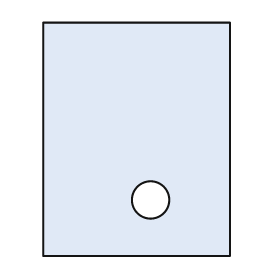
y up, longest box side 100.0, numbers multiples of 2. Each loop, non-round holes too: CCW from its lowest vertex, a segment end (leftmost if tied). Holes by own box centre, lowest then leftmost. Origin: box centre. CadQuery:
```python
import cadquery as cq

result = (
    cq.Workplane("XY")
    .moveTo(-40.0, -50.0)
    .lineTo(40.0, -50.0)
    .lineTo(40.0, 50.0)
    .lineTo(-40.0, 50.0)
    .close()
    .moveTo(6.0, -26.0)
    .circle(8.0)
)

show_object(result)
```